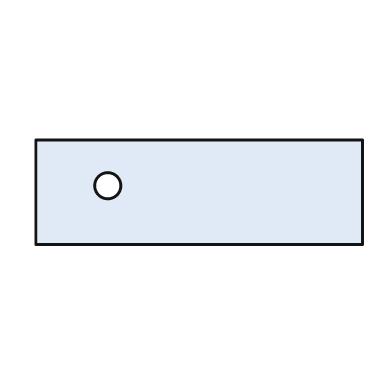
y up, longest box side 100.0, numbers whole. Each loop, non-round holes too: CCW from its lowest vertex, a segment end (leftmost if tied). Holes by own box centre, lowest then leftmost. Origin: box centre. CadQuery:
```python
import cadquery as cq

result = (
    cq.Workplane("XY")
    .moveTo(-50.0, -16.0)
    .lineTo(50.0, -16.0)
    .lineTo(50.0, 16.0)
    .lineTo(-50.0, 16.0)
    .close()
    .moveTo(-28.0, 2.0)
    .circle(4.0)
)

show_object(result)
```